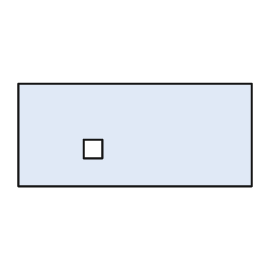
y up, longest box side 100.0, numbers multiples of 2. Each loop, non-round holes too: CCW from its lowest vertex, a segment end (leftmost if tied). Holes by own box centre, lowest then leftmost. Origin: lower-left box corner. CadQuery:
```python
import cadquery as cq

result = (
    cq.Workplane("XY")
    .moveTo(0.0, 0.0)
    .lineTo(100.0, 0.0)
    .lineTo(100.0, 44.0)
    .lineTo(0.0, 44.0)
    .close()
    .moveTo(28.0, 12.0)
    .lineTo(36.0, 12.0)
    .lineTo(36.0, 20.0)
    .lineTo(28.0, 20.0)
    .close()
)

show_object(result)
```